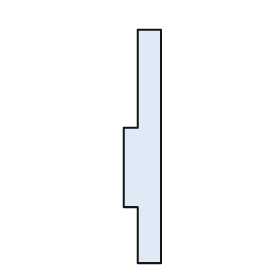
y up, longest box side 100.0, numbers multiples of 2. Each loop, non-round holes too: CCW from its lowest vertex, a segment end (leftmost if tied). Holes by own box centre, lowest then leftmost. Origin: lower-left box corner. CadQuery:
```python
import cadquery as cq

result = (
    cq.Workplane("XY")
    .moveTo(6.0, 0.0)
    .lineTo(16.0, 0.0)
    .lineTo(16.0, 100.0)
    .lineTo(6.0, 100.0)
    .lineTo(6.0, 58.0)
    .lineTo(0.0, 58.0)
    .lineTo(0.0, 24.0)
    .lineTo(6.0, 24.0)
    .close()
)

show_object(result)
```